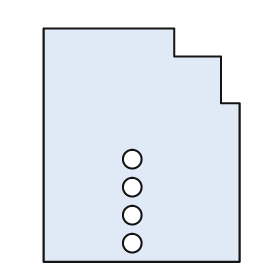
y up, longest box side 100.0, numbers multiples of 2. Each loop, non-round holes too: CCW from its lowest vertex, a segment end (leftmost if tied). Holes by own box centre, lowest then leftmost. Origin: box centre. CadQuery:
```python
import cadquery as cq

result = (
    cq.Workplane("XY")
    .moveTo(-42.0, -50.0)
    .lineTo(42.0, -50.0)
    .lineTo(42.0, 18.0)
    .lineTo(34.0, 18.0)
    .lineTo(34.0, 38.0)
    .lineTo(14.0, 38.0)
    .lineTo(14.0, 50.0)
    .lineTo(-42.0, 50.0)
    .close()
    .moveTo(-4.0, -42.0)
    .circle(4.0)
    .moveTo(-4.0, -30.0)
    .circle(4.0)
    .moveTo(-4.0, -18.0)
    .circle(4.0)
    .moveTo(-4.0, -6.0)
    .circle(4.0)
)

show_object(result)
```